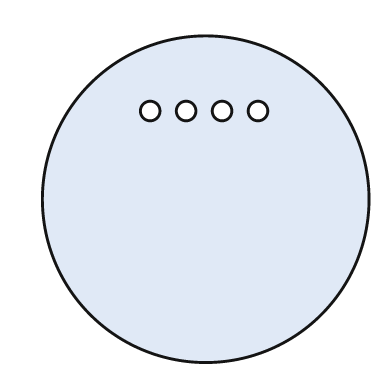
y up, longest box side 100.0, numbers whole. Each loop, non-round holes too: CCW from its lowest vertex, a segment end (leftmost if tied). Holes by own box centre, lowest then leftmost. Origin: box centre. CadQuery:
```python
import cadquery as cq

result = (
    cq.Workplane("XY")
    .moveTo(0.0, 0.0)
    .circle(50.0)
    .moveTo(-17.0, 27.0)
    .circle(3.0)
    .moveTo(-6.0, 27.0)
    .circle(3.0)
    .moveTo(5.0, 27.0)
    .circle(3.0)
    .moveTo(16.0, 27.0)
    .circle(3.0)
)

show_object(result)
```